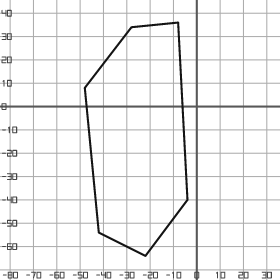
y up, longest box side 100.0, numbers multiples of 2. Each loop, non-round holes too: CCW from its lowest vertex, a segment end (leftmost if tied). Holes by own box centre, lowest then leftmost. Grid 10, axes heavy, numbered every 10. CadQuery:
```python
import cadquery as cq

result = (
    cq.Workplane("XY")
    .moveTo(-22.0, -64.0)
    .lineTo(-4.0, -40.0)
    .lineTo(-8.0, 36.0)
    .lineTo(-28.0, 34.0)
    .lineTo(-48.0, 8.0)
    .lineTo(-42.0, -54.0)
    .close()
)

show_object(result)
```